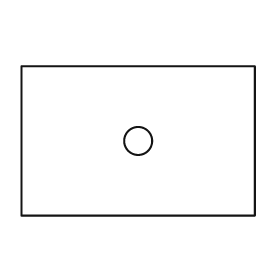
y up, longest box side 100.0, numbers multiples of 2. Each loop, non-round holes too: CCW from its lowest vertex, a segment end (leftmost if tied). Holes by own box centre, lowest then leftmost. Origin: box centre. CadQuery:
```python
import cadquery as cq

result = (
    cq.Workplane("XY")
    .moveTo(-50.0, -32.0)
    .lineTo(50.0, -32.0)
    .lineTo(50.0, 32.0)
    .lineTo(-50.0, 32.0)
    .close()
    .moveTo(0.0, 0.0)
    .circle(6.0)
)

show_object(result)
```